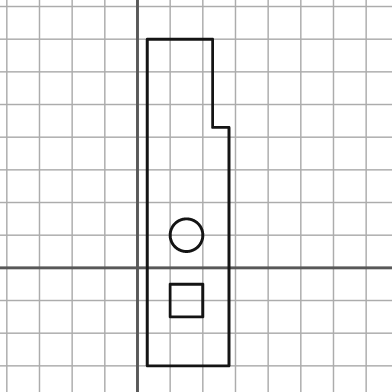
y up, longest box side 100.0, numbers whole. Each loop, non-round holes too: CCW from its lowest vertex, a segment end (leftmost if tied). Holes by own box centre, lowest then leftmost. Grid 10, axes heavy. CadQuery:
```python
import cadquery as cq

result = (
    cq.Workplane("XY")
    .moveTo(3.0, -30.0)
    .lineTo(28.0, -30.0)
    .lineTo(28.0, 43.0)
    .lineTo(23.0, 43.0)
    .lineTo(23.0, 70.0)
    .lineTo(3.0, 70.0)
    .close()
    .moveTo(10.0, -15.0)
    .lineTo(20.0, -15.0)
    .lineTo(20.0, -5.0)
    .lineTo(10.0, -5.0)
    .close()
    .moveTo(15.0, 10.0)
    .circle(5.0)
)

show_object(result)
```